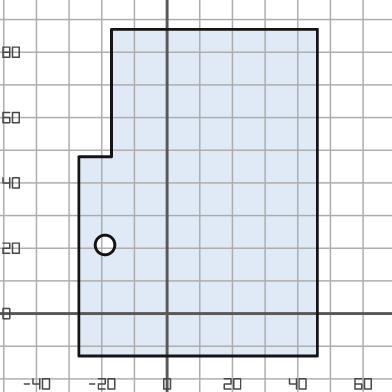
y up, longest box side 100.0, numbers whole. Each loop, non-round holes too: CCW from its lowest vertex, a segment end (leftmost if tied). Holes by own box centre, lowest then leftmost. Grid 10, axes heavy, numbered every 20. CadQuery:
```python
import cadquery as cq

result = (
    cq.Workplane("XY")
    .moveTo(-27.0, -13.0)
    .lineTo(46.0, -13.0)
    .lineTo(46.0, 87.0)
    .lineTo(-17.0, 87.0)
    .lineTo(-17.0, 48.0)
    .lineTo(-27.0, 48.0)
    .close()
    .moveTo(-19.0, 21.0)
    .circle(3.0)
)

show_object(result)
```